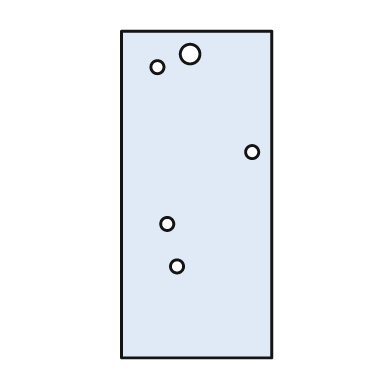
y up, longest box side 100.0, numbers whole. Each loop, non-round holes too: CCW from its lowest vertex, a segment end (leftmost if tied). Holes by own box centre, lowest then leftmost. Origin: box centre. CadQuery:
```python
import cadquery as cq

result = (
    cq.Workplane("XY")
    .moveTo(-23.0, -50.0)
    .lineTo(23.0, -50.0)
    .lineTo(23.0, 50.0)
    .lineTo(-23.0, 50.0)
    .close()
    .moveTo(-6.0, -22.0)
    .circle(2.0)
    .moveTo(-9.0, -9.0)
    .circle(2.0)
    .moveTo(17.0, 13.0)
    .circle(2.0)
    .moveTo(-12.0, 39.0)
    .circle(2.0)
    .moveTo(-2.0, 43.0)
    .circle(3.0)
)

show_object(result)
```